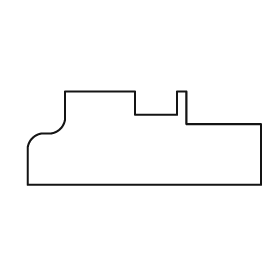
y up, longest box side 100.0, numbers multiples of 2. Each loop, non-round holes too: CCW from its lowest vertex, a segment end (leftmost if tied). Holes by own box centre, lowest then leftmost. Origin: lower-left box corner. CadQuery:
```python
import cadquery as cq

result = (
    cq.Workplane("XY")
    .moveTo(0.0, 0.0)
    .lineTo(100.0, 0.0)
    .lineTo(100.0, 26.0)
    .lineTo(68.0, 26.0)
    .lineTo(68.0, 40.0)
    .lineTo(64.0, 40.0)
    .lineTo(64.0, 30.0)
    .lineTo(46.0, 30.0)
    .lineTo(46.0, 40.0)
    .lineTo(16.0, 40.0)
    .lineTo(16.0, 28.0)
    .threePointArc((14.0, 24.0), (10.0, 22.0))
    .lineTo(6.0, 22.0)
    .threePointArc((2.0, 20.0), (0.0, 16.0))
    .close()
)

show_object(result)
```